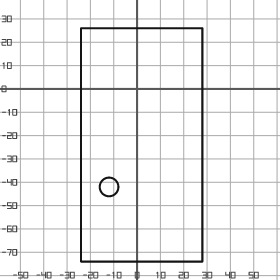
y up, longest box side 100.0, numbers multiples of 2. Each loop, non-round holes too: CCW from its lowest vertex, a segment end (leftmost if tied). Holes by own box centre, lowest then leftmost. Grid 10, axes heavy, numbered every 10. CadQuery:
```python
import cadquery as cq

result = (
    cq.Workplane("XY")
    .moveTo(-24.0, -74.0)
    .lineTo(28.0, -74.0)
    .lineTo(28.0, 26.0)
    .lineTo(-24.0, 26.0)
    .close()
    .moveTo(-12.0, -42.0)
    .circle(4.0)
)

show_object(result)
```